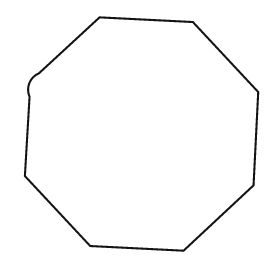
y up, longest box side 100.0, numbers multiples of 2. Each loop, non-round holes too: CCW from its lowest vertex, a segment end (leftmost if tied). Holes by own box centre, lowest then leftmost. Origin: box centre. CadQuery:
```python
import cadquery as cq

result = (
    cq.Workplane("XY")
    .moveTo(18.0, -50.0)
    .lineTo(48.0, -22.0)
    .lineTo(50.0, 18.0)
    .lineTo(22.0, 48.0)
    .lineTo(-18.0, 50.0)
    .lineTo(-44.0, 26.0)
    .threePointArc((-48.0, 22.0), (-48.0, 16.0))
    .lineTo(-50.0, -18.0)
    .lineTo(-22.0, -48.0)
    .close()
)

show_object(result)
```